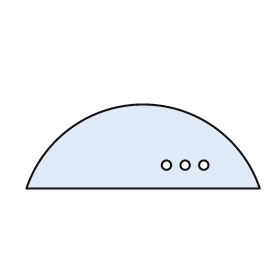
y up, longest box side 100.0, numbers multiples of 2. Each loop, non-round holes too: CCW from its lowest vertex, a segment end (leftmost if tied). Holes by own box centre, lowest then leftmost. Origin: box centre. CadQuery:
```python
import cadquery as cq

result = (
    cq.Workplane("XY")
    .moveTo(-50.0, -18.0)
    .lineTo(50.0, -18.0)
    .threePointArc((0.0, 18.0), (-50.0, -18.0))
    .close()
    .moveTo(10.0, -8.0)
    .circle(2.0)
    .moveTo(18.0, -8.0)
    .circle(2.0)
    .moveTo(26.0, -8.0)
    .circle(2.0)
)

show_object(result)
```